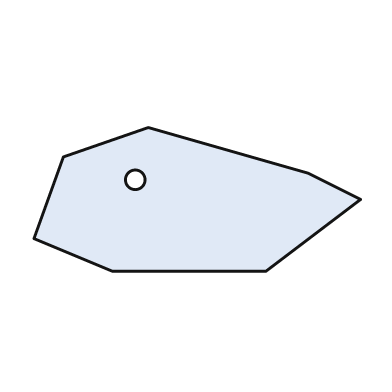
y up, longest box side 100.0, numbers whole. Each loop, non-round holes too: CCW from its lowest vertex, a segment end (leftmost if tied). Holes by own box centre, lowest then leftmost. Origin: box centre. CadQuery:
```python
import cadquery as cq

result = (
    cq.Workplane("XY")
    .moveTo(-26.0, -22.0)
    .lineTo(21.0, -22.0)
    .lineTo(50.0, 0.0)
    .lineTo(34.0, 8.0)
    .lineTo(-15.0, 22.0)
    .lineTo(-41.0, 13.0)
    .lineTo(-50.0, -12.0)
    .close()
    .moveTo(-19.0, 6.0)
    .circle(3.0)
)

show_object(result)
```